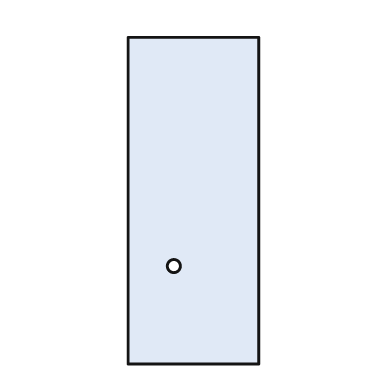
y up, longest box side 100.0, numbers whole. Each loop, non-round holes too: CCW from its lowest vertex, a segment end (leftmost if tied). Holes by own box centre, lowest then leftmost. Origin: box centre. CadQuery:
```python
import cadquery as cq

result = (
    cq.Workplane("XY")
    .moveTo(-20.0, -50.0)
    .lineTo(20.0, -50.0)
    .lineTo(20.0, 50.0)
    .lineTo(-20.0, 50.0)
    .close()
    .moveTo(-6.0, -20.0)
    .circle(2.0)
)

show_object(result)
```